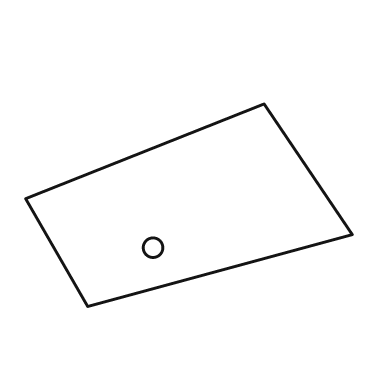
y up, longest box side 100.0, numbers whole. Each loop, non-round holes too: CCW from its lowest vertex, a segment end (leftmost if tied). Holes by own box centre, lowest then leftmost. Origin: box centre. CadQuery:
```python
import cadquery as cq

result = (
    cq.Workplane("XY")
    .moveTo(-31.0, -31.0)
    .lineTo(50.0, -9.0)
    .lineTo(23.0, 31.0)
    .lineTo(-50.0, 2.0)
    .close()
    .moveTo(-11.0, -13.0)
    .circle(3.0)
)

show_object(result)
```